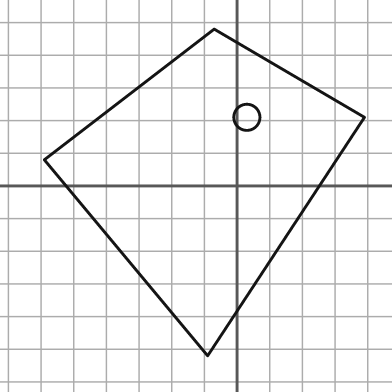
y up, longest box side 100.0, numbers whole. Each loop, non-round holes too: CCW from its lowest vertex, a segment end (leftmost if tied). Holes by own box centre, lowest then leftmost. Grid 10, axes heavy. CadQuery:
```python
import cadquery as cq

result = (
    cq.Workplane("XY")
    .moveTo(-9.0, -52.0)
    .lineTo(39.0, 21.0)
    .lineTo(-7.0, 48.0)
    .lineTo(-59.0, 8.0)
    .close()
    .moveTo(3.0, 21.0)
    .circle(4.0)
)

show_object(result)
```